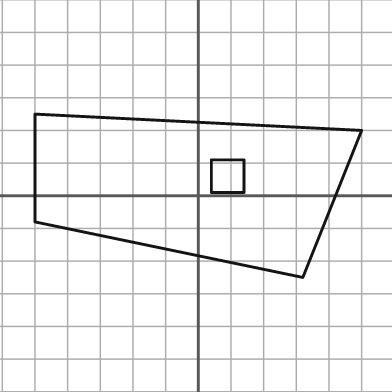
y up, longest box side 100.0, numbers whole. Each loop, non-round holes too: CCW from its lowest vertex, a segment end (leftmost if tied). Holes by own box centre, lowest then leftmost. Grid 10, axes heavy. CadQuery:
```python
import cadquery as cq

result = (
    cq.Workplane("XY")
    .moveTo(32.0, -25.0)
    .lineTo(50.0, 20.0)
    .lineTo(-50.0, 25.0)
    .lineTo(-50.0, -8.0)
    .close()
    .moveTo(4.0, 1.0)
    .lineTo(14.0, 1.0)
    .lineTo(14.0, 11.0)
    .lineTo(4.0, 11.0)
    .close()
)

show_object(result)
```